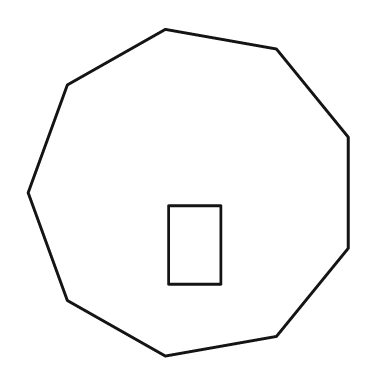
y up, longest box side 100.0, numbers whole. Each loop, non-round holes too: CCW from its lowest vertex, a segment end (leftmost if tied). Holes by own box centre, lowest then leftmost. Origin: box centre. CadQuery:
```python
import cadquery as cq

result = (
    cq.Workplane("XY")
    .moveTo(-7.0, -50.0)
    .lineTo(27.0, -44.0)
    .lineTo(49.0, -17.0)
    .lineTo(49.0, 17.0)
    .lineTo(27.0, 44.0)
    .lineTo(-7.0, 50.0)
    .lineTo(-37.0, 33.0)
    .lineTo(-49.0, 0.0)
    .lineTo(-37.0, -33.0)
    .close()
    .moveTo(-6.0, -28.0)
    .lineTo(10.0, -28.0)
    .lineTo(10.0, -4.0)
    .lineTo(-6.0, -4.0)
    .close()
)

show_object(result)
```